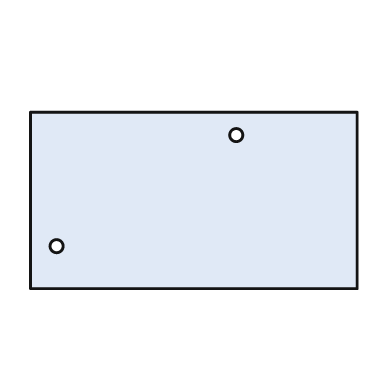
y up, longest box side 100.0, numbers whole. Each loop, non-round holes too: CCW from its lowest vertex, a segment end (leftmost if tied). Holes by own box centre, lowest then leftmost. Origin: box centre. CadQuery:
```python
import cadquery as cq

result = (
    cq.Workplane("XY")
    .moveTo(-50.0, -27.0)
    .lineTo(50.0, -27.0)
    .lineTo(50.0, 27.0)
    .lineTo(-50.0, 27.0)
    .close()
    .moveTo(-42.0, -14.0)
    .circle(2.0)
    .moveTo(13.0, 20.0)
    .circle(2.0)
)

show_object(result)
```